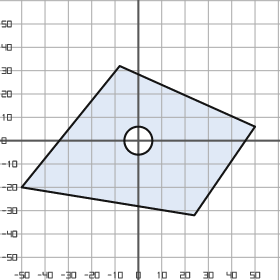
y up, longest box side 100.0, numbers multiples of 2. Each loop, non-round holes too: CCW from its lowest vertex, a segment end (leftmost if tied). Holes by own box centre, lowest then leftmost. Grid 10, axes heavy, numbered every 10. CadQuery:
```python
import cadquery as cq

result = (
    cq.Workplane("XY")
    .moveTo(24.0, -32.0)
    .lineTo(50.0, 6.0)
    .lineTo(-8.0, 32.0)
    .lineTo(-50.0, -20.0)
    .close()
    .moveTo(0.0, 0.0)
    .circle(6.0)
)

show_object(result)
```